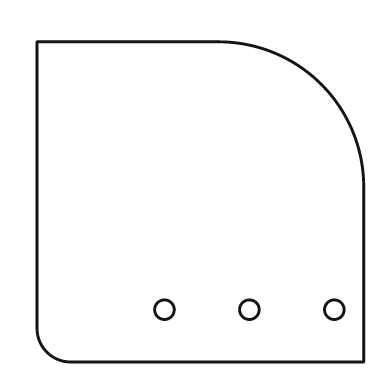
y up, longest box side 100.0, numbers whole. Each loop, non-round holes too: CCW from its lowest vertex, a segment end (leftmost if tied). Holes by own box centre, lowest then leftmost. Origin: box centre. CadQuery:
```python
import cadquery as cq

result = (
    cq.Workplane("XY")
    .moveTo(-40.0, -49.0)
    .lineTo(50.0, -49.0)
    .lineTo(50.0, 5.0)
    .threePointArc((37.0, 36.0), (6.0, 49.0))
    .lineTo(-50.0, 49.0)
    .lineTo(-50.0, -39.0)
    .threePointArc((-47.0, -46.0), (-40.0, -49.0))
    .close()
    .moveTo(-11.0, -33.0)
    .circle(3.0)
    .moveTo(15.0, -33.0)
    .circle(3.0)
    .moveTo(41.0, -33.0)
    .circle(3.0)
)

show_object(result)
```